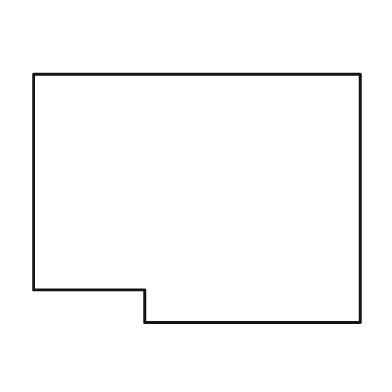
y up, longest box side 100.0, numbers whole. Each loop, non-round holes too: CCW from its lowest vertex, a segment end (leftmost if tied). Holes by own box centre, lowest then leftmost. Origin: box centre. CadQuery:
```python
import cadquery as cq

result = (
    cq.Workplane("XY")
    .moveTo(-16.0, -38.0)
    .lineTo(50.0, -38.0)
    .lineTo(50.0, 38.0)
    .lineTo(-50.0, 38.0)
    .lineTo(-50.0, -28.0)
    .lineTo(-16.0, -28.0)
    .close()
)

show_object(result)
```